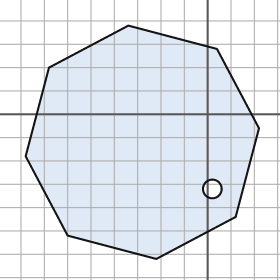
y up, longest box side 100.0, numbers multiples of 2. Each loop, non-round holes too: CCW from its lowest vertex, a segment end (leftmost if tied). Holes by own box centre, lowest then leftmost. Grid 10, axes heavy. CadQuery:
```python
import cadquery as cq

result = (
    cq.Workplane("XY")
    .moveTo(-22.0, -62.0)
    .lineTo(12.0, -44.0)
    .lineTo(22.0, -6.0)
    .lineTo(4.0, 28.0)
    .lineTo(-34.0, 38.0)
    .lineTo(-68.0, 20.0)
    .lineTo(-78.0, -18.0)
    .lineTo(-60.0, -52.0)
    .close()
    .moveTo(2.0, -32.0)
    .circle(4.0)
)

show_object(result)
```